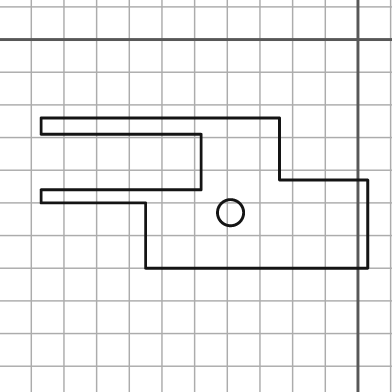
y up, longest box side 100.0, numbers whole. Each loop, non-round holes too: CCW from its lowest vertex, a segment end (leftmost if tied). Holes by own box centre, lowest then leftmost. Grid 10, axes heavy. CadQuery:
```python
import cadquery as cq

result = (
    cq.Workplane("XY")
    .moveTo(-65.0, -70.0)
    .lineTo(3.0, -70.0)
    .lineTo(3.0, -43.0)
    .lineTo(-24.0, -43.0)
    .lineTo(-24.0, -24.0)
    .lineTo(-97.0, -24.0)
    .lineTo(-97.0, -29.0)
    .lineTo(-48.0, -29.0)
    .lineTo(-48.0, -46.0)
    .lineTo(-97.0, -46.0)
    .lineTo(-97.0, -50.0)
    .lineTo(-65.0, -50.0)
    .close()
    .moveTo(-39.0, -53.0)
    .circle(4.0)
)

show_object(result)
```